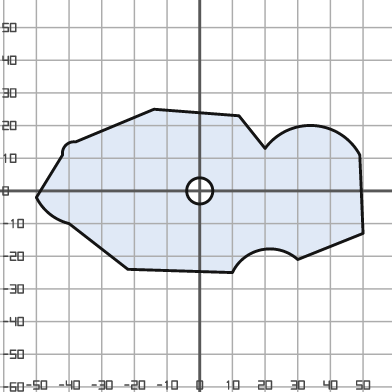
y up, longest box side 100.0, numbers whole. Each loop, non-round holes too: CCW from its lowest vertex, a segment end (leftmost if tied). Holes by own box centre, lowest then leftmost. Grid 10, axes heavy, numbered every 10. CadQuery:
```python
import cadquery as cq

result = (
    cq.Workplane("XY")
    .moveTo(10.0, -25.0)
    .threePointArc((19.0, -18.0), (30.0, -21.0))
    .lineTo(50.0, -13.0)
    .lineTo(49.0, 11.0)
    .threePointArc((35.0, 20.0), (20.0, 13.0))
    .lineTo(12.0, 23.0)
    .lineTo(-14.0, 25.0)
    .lineTo(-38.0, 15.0)
    .threePointArc((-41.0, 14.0), (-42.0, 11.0))
    .lineTo(-50.0, -2.0)
    .threePointArc((-46.0, -7.0), (-40.0, -10.0))
    .lineTo(-22.0, -24.0)
    .close()
    .moveTo(0.0, 0.0)
    .circle(4.0)
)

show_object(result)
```